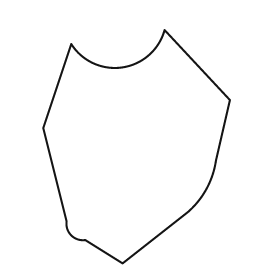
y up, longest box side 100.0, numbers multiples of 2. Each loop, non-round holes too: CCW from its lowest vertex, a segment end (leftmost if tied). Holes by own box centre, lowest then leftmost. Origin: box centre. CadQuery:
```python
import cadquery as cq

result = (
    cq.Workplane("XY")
    .moveTo(-6.0, -50.0)
    .lineTo(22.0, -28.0)
    .threePointArc((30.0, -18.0), (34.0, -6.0))
    .lineTo(40.0, 20.0)
    .lineTo(12.0, 50.0)
    .threePointArc((-6.0, 34.0), (-28.0, 44.0))
    .lineTo(-40.0, 8.0)
    .lineTo(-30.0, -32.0)
    .threePointArc((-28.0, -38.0), (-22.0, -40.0))
    .close()
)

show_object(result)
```